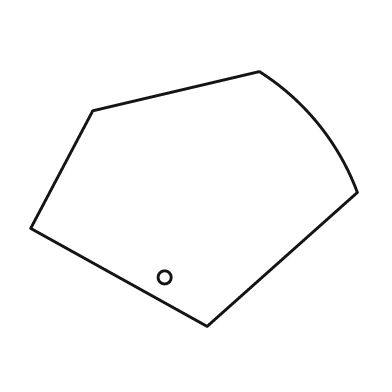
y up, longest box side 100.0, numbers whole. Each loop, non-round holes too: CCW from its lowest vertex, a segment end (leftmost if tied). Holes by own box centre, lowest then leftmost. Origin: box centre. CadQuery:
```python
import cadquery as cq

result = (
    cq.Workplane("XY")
    .moveTo(4.0, -39.0)
    .lineTo(50.0, 2.0)
    .threePointArc((38.0, 23.0), (20.0, 39.0))
    .lineTo(-31.0, 27.0)
    .lineTo(-50.0, -9.0)
    .close()
    .moveTo(-9.0, -24.0)
    .circle(2.0)
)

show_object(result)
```